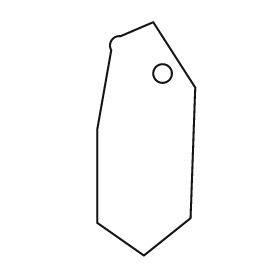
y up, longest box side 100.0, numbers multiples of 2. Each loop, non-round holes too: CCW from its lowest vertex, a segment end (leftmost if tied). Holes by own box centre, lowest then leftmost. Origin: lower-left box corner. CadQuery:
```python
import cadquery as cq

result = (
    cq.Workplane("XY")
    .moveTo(20.0, 0.0)
    .lineTo(40.0, 16.0)
    .lineTo(42.0, 72.0)
    .lineTo(24.0, 100.0)
    .lineTo(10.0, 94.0)
    .threePointArc((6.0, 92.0), (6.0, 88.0))
    .lineTo(0.0, 54.0)
    .lineTo(0.0, 14.0)
    .close()
    .moveTo(28.0, 78.0)
    .circle(4.0)
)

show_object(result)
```